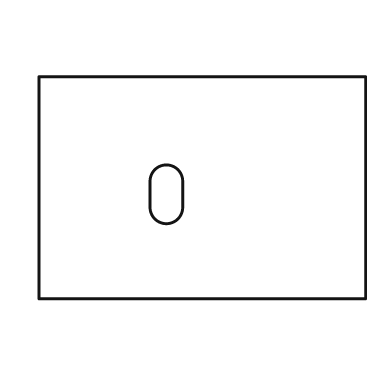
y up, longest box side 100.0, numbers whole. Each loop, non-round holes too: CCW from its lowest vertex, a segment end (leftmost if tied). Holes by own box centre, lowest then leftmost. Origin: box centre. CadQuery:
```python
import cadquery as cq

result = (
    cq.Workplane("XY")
    .moveTo(-50.0, -34.0)
    .lineTo(50.0, -34.0)
    .lineTo(50.0, 34.0)
    .lineTo(-50.0, 34.0)
    .close()
    .moveTo(-16.0, -6.0)
    .threePointArc((-11.0, -11.0), (-6.0, -6.0))
    .lineTo(-6.0, 2.0)
    .threePointArc((-11.0, 7.0), (-16.0, 2.0))
    .close()
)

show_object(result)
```